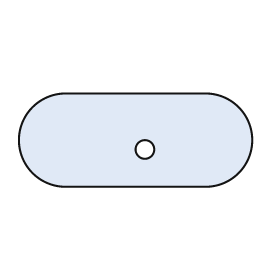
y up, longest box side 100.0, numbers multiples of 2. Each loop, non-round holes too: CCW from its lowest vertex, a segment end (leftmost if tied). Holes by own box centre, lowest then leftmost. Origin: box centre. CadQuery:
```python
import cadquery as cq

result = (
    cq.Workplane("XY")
    .moveTo(-30.0, -20.0)
    .lineTo(30.0, -20.0)
    .threePointArc((50.0, 0.0), (30.0, 20.0))
    .lineTo(-30.0, 20.0)
    .threePointArc((-50.0, 0.0), (-30.0, -20.0))
    .close()
    .moveTo(4.0, -4.0)
    .circle(4.0)
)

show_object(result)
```